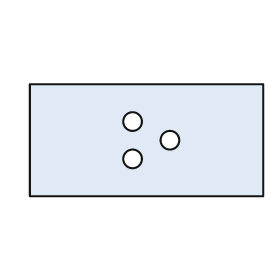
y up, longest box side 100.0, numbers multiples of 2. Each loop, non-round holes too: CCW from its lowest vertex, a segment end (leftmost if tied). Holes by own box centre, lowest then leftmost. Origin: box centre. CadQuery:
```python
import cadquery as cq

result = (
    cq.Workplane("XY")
    .moveTo(-50.0, -24.0)
    .lineTo(50.0, -24.0)
    .lineTo(50.0, 24.0)
    .lineTo(-50.0, 24.0)
    .close()
    .moveTo(-6.0, -8.0)
    .circle(4.0)
    .moveTo(10.0, 0.0)
    .circle(4.0)
    .moveTo(-6.0, 8.0)
    .circle(4.0)
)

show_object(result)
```